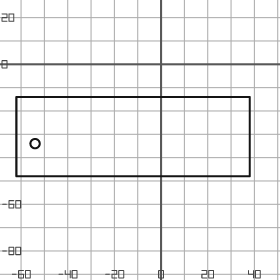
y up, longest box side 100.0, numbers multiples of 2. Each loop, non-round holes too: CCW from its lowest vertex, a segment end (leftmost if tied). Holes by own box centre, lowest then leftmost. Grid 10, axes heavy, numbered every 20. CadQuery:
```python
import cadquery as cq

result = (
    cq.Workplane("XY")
    .moveTo(-62.0, -48.0)
    .lineTo(38.0, -48.0)
    .lineTo(38.0, -14.0)
    .lineTo(-62.0, -14.0)
    .close()
    .moveTo(-54.0, -34.0)
    .circle(2.0)
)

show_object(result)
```